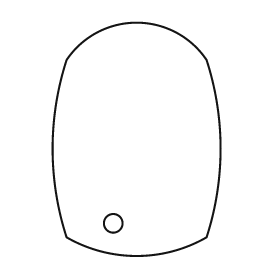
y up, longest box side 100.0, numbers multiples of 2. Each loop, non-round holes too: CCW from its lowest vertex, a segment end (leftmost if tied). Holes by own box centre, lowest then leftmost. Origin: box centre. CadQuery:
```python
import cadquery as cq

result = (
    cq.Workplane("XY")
    .moveTo(-30.0, -42.0)
    .threePointArc((0.0, -50.0), (30.0, -42.0))
    .threePointArc((36.0, -4.0), (30.0, 34.0))
    .threePointArc((0.0, 50.0), (-30.0, 34.0))
    .threePointArc((-36.0, -4.0), (-30.0, -42.0))
    .close()
    .moveTo(-10.0, -36.0)
    .circle(4.0)
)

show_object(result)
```